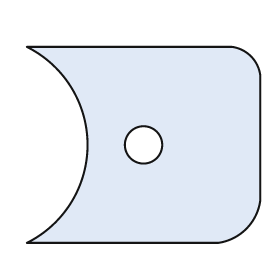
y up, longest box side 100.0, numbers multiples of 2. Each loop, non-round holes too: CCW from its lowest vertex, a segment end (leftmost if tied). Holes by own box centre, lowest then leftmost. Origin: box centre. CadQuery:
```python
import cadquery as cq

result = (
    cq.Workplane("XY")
    .moveTo(-50.0, -42.0)
    .lineTo(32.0, -42.0)
    .threePointArc((44.0, -36.0), (50.0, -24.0))
    .lineTo(50.0, 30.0)
    .threePointArc((46.0, 38.0), (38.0, 42.0))
    .lineTo(-50.0, 42.0)
    .threePointArc((-24.0, 0.0), (-50.0, -42.0))
    .close()
    .moveTo(0.0, 0.0)
    .circle(8.0)
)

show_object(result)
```